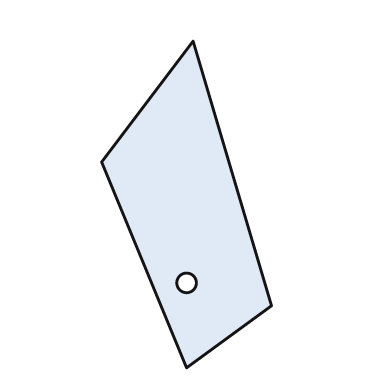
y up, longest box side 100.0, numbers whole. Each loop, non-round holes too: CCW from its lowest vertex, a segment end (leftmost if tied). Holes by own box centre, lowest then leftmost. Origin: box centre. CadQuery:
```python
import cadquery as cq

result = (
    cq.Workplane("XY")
    .moveTo(0.0, -50.0)
    .lineTo(26.0, -31.0)
    .lineTo(2.0, 50.0)
    .lineTo(-26.0, 13.0)
    .close()
    .moveTo(0.0, -24.0)
    .circle(3.0)
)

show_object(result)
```